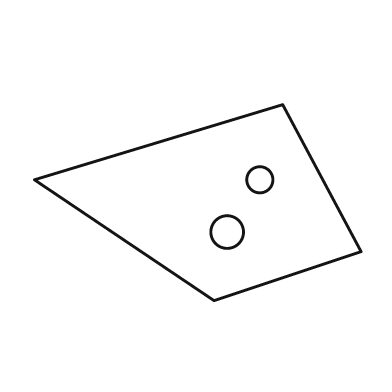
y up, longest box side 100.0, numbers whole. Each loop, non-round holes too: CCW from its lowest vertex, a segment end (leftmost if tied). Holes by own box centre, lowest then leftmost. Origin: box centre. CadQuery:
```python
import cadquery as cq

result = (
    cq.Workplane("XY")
    .moveTo(5.0, -30.0)
    .lineTo(50.0, -15.0)
    .lineTo(26.0, 30.0)
    .lineTo(-50.0, 7.0)
    .close()
    .moveTo(9.0, -9.0)
    .circle(5.0)
    .moveTo(19.0, 7.0)
    .circle(4.0)
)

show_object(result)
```